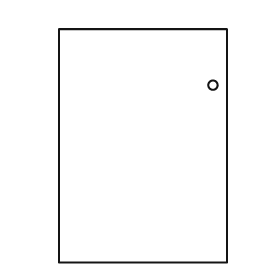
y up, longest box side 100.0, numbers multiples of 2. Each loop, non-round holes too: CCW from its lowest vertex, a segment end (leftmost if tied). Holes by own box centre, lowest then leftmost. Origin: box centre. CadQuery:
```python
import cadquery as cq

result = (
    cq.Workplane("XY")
    .moveTo(-36.0, -50.0)
    .lineTo(36.0, -50.0)
    .lineTo(36.0, 50.0)
    .lineTo(-36.0, 50.0)
    .close()
    .moveTo(30.0, 26.0)
    .circle(2.0)
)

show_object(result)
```